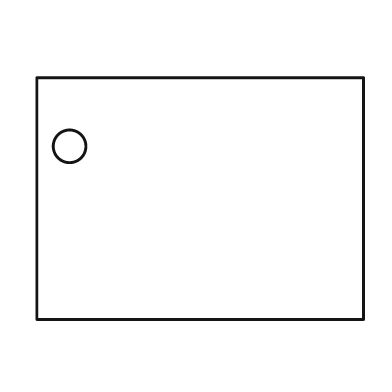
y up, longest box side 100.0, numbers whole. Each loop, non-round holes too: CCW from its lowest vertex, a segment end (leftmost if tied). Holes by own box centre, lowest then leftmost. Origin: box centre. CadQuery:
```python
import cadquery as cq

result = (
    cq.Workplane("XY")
    .moveTo(-50.0, -37.0)
    .lineTo(50.0, -37.0)
    .lineTo(50.0, 37.0)
    .lineTo(-50.0, 37.0)
    .close()
    .moveTo(-40.0, 16.0)
    .circle(5.0)
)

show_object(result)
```